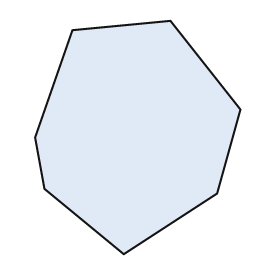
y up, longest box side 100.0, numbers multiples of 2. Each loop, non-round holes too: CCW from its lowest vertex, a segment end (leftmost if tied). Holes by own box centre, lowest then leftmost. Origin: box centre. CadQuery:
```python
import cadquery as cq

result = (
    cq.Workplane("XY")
    .moveTo(-6.0, -50.0)
    .lineTo(34.0, -24.0)
    .lineTo(44.0, 12.0)
    .lineTo(14.0, 50.0)
    .lineTo(-28.0, 46.0)
    .lineTo(-44.0, 0.0)
    .lineTo(-40.0, -22.0)
    .close()
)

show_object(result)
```